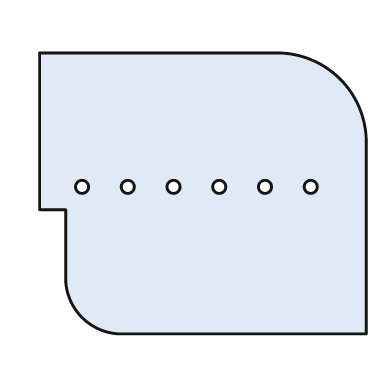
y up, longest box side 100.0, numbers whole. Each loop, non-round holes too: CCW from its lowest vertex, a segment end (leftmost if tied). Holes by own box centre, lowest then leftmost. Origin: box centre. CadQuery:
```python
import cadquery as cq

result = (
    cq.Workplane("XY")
    .moveTo(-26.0, -43.0)
    .lineTo(50.0, -43.0)
    .lineTo(50.0, 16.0)
    .threePointArc((42.0, 35.0), (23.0, 43.0))
    .lineTo(-50.0, 43.0)
    .lineTo(-50.0, -5.0)
    .lineTo(-42.0, -5.0)
    .lineTo(-42.0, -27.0)
    .threePointArc((-37.0, -38.0), (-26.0, -43.0))
    .close()
    .moveTo(-37.0, 2.0)
    .circle(2.0)
    .moveTo(-23.0, 2.0)
    .circle(2.0)
    .moveTo(-9.0, 2.0)
    .circle(2.0)
    .moveTo(5.0, 2.0)
    .circle(2.0)
    .moveTo(19.0, 2.0)
    .circle(2.0)
    .moveTo(33.0, 2.0)
    .circle(2.0)
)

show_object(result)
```